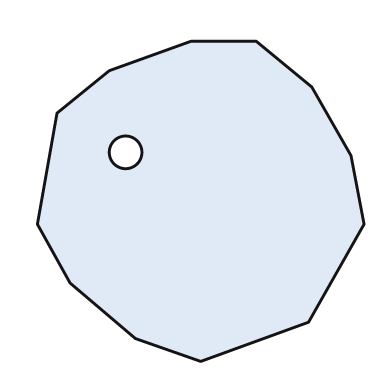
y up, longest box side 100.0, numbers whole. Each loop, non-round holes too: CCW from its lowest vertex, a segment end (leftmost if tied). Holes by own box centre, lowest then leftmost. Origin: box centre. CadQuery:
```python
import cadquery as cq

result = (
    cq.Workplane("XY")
    .moveTo(0.0, -49.0)
    .lineTo(33.0, -37.0)
    .lineTo(50.0, -7.0)
    .lineTo(46.0, 14.0)
    .lineTo(34.0, 35.0)
    .lineTo(17.0, 49.0)
    .lineTo(-3.0, 49.0)
    .lineTo(-28.0, 40.0)
    .lineTo(-44.0, 27.0)
    .lineTo(-50.0, -7.0)
    .lineTo(-40.0, -25.0)
    .lineTo(-20.0, -42.0)
    .close()
    .moveTo(-23.0, 15.0)
    .circle(5.0)
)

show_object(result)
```